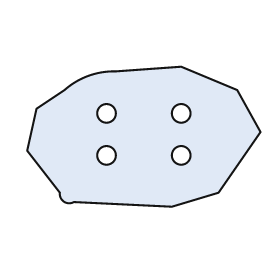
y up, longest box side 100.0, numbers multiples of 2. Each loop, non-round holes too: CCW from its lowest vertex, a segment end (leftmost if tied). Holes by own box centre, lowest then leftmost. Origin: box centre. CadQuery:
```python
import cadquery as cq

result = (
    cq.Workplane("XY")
    .moveTo(12.0, -30.0)
    .lineTo(32.0, -24.0)
    .lineTo(50.0, 2.0)
    .lineTo(40.0, 20.0)
    .lineTo(16.0, 30.0)
    .lineTo(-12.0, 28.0)
    .threePointArc((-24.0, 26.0), (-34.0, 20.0))
    .lineTo(-46.0, 12.0)
    .lineTo(-50.0, -6.0)
    .lineTo(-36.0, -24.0)
    .threePointArc((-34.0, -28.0), (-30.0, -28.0))
    .close()
    .moveTo(-16.0, -8.0)
    .circle(4.0)
    .moveTo(16.0, -8.0)
    .circle(4.0)
    .moveTo(-16.0, 10.0)
    .circle(4.0)
    .moveTo(16.0, 10.0)
    .circle(4.0)
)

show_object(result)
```